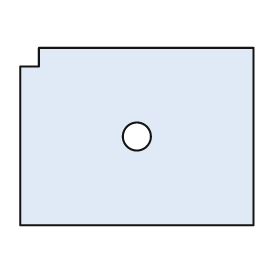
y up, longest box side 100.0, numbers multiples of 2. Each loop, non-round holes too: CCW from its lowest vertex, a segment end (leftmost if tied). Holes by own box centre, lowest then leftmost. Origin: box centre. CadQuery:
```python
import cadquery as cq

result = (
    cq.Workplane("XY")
    .moveTo(-50.0, -38.0)
    .lineTo(50.0, -38.0)
    .lineTo(50.0, 38.0)
    .lineTo(-42.0, 38.0)
    .lineTo(-42.0, 30.0)
    .lineTo(-50.0, 30.0)
    .close()
    .moveTo(0.0, 0.0)
    .circle(6.0)
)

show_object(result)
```